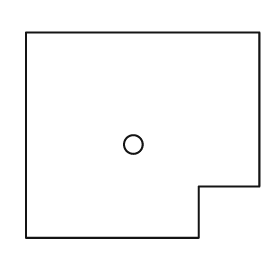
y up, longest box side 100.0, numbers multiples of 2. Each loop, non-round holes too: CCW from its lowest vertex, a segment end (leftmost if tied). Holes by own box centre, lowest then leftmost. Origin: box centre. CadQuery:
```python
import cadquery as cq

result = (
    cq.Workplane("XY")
    .moveTo(-50.0, -44.0)
    .lineTo(24.0, -44.0)
    .lineTo(24.0, -22.0)
    .lineTo(50.0, -22.0)
    .lineTo(50.0, 44.0)
    .lineTo(-50.0, 44.0)
    .close()
    .moveTo(-4.0, -4.0)
    .circle(4.0)
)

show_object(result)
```